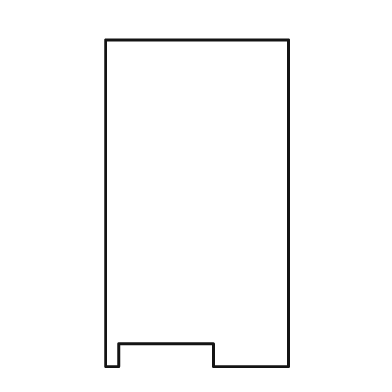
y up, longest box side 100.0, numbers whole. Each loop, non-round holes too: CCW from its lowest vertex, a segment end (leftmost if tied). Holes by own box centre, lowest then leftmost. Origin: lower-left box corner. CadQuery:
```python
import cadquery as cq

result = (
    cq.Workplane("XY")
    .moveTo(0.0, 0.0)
    .lineTo(4.0, 0.0)
    .lineTo(4.0, 7.0)
    .lineTo(33.0, 7.0)
    .lineTo(33.0, 0.0)
    .lineTo(56.0, 0.0)
    .lineTo(56.0, 100.0)
    .lineTo(0.0, 100.0)
    .close()
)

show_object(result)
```